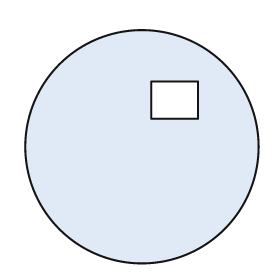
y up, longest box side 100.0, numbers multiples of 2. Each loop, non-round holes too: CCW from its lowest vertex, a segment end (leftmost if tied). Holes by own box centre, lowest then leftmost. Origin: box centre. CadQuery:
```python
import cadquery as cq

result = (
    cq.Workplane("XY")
    .moveTo(0.0, 0.0)
    .circle(50.0)
    .moveTo(4.0, 12.0)
    .lineTo(24.0, 12.0)
    .lineTo(24.0, 28.0)
    .lineTo(4.0, 28.0)
    .close()
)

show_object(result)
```